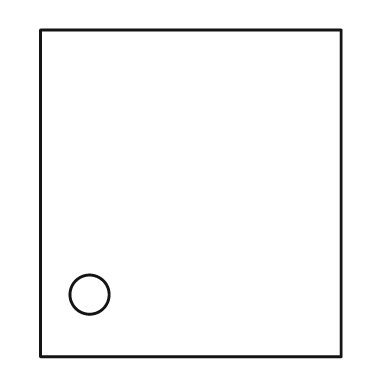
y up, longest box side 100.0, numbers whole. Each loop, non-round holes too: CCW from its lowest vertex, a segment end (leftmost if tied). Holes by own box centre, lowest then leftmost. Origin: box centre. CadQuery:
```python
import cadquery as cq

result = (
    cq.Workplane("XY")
    .moveTo(-46.0, -50.0)
    .lineTo(46.0, -50.0)
    .lineTo(46.0, 50.0)
    .lineTo(-46.0, 50.0)
    .close()
    .moveTo(-31.0, -31.0)
    .circle(6.0)
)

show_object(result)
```